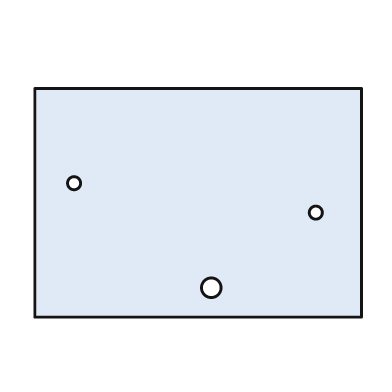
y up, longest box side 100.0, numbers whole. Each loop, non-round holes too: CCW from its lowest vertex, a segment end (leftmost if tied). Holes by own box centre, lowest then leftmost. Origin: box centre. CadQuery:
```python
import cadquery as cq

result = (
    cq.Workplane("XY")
    .moveTo(-50.0, -35.0)
    .lineTo(50.0, -35.0)
    .lineTo(50.0, 35.0)
    .lineTo(-50.0, 35.0)
    .close()
    .moveTo(4.0, -26.0)
    .circle(3.0)
    .moveTo(36.0, -3.0)
    .circle(2.0)
    .moveTo(-38.0, 6.0)
    .circle(2.0)
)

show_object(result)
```